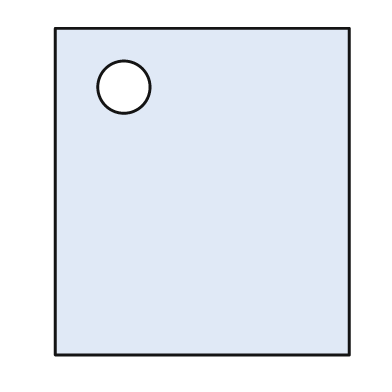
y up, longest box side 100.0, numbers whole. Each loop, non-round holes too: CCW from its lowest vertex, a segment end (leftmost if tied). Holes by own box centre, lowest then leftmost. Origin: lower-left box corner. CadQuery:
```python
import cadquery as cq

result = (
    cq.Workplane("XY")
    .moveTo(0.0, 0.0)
    .lineTo(90.0, 0.0)
    .lineTo(90.0, 100.0)
    .lineTo(0.0, 100.0)
    .close()
    .moveTo(21.0, 82.0)
    .circle(8.0)
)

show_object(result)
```